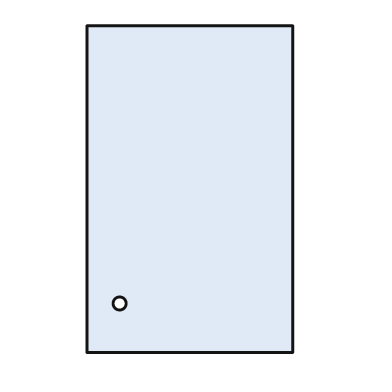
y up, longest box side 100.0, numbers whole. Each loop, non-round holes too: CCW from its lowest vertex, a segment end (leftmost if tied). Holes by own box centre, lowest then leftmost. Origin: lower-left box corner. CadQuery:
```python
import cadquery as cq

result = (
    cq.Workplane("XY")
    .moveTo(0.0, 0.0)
    .lineTo(63.0, 0.0)
    .lineTo(63.0, 100.0)
    .lineTo(0.0, 100.0)
    .close()
    .moveTo(10.0, 15.0)
    .circle(2.0)
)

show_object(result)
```